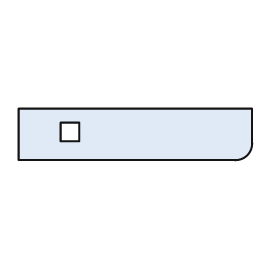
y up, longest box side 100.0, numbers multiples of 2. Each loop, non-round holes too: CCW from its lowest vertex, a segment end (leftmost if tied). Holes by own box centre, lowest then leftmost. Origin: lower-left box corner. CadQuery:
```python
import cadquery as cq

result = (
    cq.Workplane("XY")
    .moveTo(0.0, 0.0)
    .lineTo(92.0, 0.0)
    .threePointArc((98.0, 2.0), (100.0, 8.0))
    .lineTo(100.0, 22.0)
    .lineTo(0.0, 22.0)
    .close()
    .moveTo(18.0, 8.0)
    .lineTo(26.0, 8.0)
    .lineTo(26.0, 16.0)
    .lineTo(18.0, 16.0)
    .close()
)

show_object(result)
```